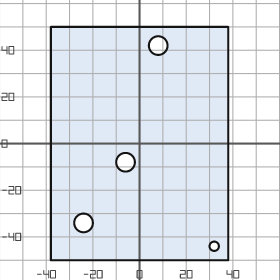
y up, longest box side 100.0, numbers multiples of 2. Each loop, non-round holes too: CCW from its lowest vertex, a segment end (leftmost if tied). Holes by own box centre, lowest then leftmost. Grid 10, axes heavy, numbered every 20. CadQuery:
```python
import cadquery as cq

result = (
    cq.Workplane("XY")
    .moveTo(-38.0, -50.0)
    .lineTo(38.0, -50.0)
    .lineTo(38.0, 50.0)
    .lineTo(-38.0, 50.0)
    .close()
    .moveTo(32.0, -44.0)
    .circle(2.0)
    .moveTo(-24.0, -34.0)
    .circle(4.0)
    .moveTo(-6.0, -8.0)
    .circle(4.0)
    .moveTo(8.0, 42.0)
    .circle(4.0)
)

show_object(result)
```